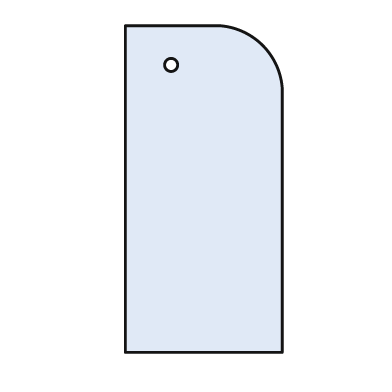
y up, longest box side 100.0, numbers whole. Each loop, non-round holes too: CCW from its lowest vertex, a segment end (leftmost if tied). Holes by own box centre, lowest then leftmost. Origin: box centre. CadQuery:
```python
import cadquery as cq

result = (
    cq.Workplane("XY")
    .moveTo(-24.0, -50.0)
    .lineTo(24.0, -50.0)
    .lineTo(24.0, 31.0)
    .threePointArc((18.0, 44.0), (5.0, 50.0))
    .lineTo(-24.0, 50.0)
    .close()
    .moveTo(-10.0, 38.0)
    .circle(2.0)
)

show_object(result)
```